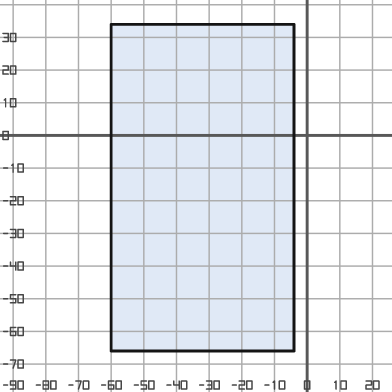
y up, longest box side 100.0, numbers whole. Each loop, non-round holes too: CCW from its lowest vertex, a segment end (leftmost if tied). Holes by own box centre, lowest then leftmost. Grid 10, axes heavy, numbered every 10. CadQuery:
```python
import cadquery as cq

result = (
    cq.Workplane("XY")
    .moveTo(-60.0, -66.0)
    .lineTo(-4.0, -66.0)
    .lineTo(-4.0, 34.0)
    .lineTo(-60.0, 34.0)
    .close()
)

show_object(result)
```